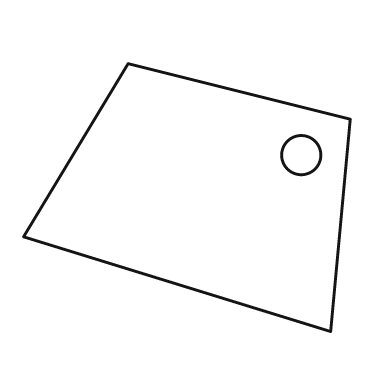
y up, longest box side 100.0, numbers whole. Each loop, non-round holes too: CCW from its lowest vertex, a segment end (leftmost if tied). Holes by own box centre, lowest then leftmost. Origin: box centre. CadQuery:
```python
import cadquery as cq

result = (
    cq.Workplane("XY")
    .moveTo(44.0, -41.0)
    .lineTo(50.0, 24.0)
    .lineTo(-18.0, 41.0)
    .lineTo(-50.0, -12.0)
    .close()
    .moveTo(35.0, 13.0)
    .circle(6.0)
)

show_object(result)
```